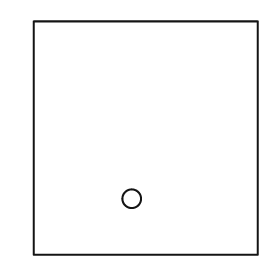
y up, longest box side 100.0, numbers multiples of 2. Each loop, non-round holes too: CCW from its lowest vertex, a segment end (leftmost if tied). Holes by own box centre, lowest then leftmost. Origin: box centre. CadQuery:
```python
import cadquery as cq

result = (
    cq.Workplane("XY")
    .moveTo(-48.0, -50.0)
    .lineTo(48.0, -50.0)
    .lineTo(48.0, 50.0)
    .lineTo(-48.0, 50.0)
    .close()
    .moveTo(-6.0, -26.0)
    .circle(4.0)
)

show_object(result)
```